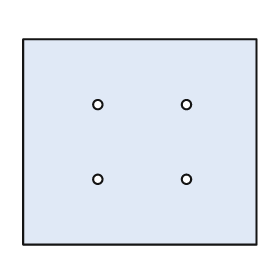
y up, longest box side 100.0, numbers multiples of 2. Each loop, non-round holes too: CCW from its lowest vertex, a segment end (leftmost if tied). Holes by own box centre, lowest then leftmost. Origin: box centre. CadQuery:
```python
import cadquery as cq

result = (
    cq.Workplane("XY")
    .moveTo(-50.0, -44.0)
    .lineTo(50.0, -44.0)
    .lineTo(50.0, 44.0)
    .lineTo(-50.0, 44.0)
    .close()
    .moveTo(-18.0, -16.0)
    .circle(2.0)
    .moveTo(20.0, -16.0)
    .circle(2.0)
    .moveTo(-18.0, 16.0)
    .circle(2.0)
    .moveTo(20.0, 16.0)
    .circle(2.0)
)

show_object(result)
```